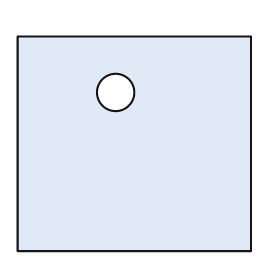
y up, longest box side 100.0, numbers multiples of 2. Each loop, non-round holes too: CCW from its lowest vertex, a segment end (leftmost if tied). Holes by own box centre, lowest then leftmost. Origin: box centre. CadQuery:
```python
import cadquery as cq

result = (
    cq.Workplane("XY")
    .moveTo(-50.0, -46.0)
    .lineTo(50.0, -46.0)
    .lineTo(50.0, 46.0)
    .lineTo(-50.0, 46.0)
    .close()
    .moveTo(-8.0, 22.0)
    .circle(8.0)
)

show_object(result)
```